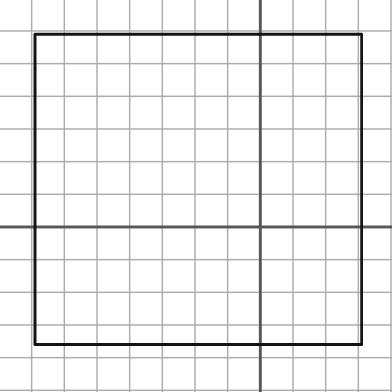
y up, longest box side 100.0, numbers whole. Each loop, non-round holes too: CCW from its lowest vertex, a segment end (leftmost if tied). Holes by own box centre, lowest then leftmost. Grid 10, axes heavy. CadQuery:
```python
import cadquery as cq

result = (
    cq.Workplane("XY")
    .moveTo(-69.0, -36.0)
    .lineTo(31.0, -36.0)
    .lineTo(31.0, 59.0)
    .lineTo(-69.0, 59.0)
    .close()
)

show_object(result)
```